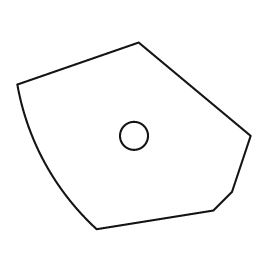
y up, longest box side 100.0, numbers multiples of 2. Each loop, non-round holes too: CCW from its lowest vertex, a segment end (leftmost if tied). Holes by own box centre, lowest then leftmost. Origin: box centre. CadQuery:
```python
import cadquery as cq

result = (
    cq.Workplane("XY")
    .moveTo(-16.0, -40.0)
    .lineTo(34.0, -32.0)
    .lineTo(42.0, -24.0)
    .lineTo(50.0, 0.0)
    .lineTo(2.0, 40.0)
    .lineTo(-50.0, 22.0)
    .threePointArc((-38.0, -12.0), (-16.0, -40.0))
    .close()
    .moveTo(0.0, 0.0)
    .circle(6.0)
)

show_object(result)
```